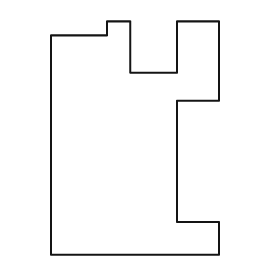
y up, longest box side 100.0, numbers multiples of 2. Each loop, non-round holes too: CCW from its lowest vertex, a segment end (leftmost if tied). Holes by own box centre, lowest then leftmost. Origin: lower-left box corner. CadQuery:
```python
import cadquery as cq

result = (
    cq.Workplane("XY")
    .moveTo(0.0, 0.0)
    .lineTo(72.0, 0.0)
    .lineTo(72.0, 14.0)
    .lineTo(54.0, 14.0)
    .lineTo(54.0, 66.0)
    .lineTo(72.0, 66.0)
    .lineTo(72.0, 100.0)
    .lineTo(54.0, 100.0)
    .lineTo(54.0, 78.0)
    .lineTo(34.0, 78.0)
    .lineTo(34.0, 100.0)
    .lineTo(24.0, 100.0)
    .lineTo(24.0, 94.0)
    .lineTo(0.0, 94.0)
    .close()
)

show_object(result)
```